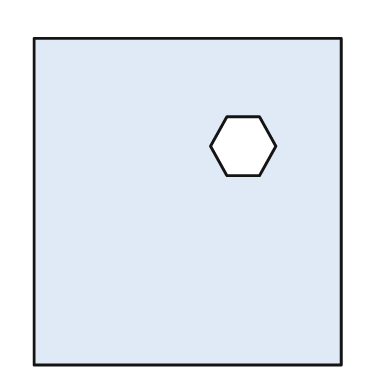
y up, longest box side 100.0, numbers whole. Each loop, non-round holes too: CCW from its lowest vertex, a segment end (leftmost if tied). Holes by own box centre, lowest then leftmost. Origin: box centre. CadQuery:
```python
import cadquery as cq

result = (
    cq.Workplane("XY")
    .moveTo(-47.0, -50.0)
    .lineTo(47.0, -50.0)
    .lineTo(47.0, 50.0)
    .lineTo(-47.0, 50.0)
    .close()
    .moveTo(12.0, 8.0)
    .lineTo(22.0, 8.0)
    .lineTo(27.0, 17.0)
    .lineTo(22.0, 26.0)
    .lineTo(12.0, 26.0)
    .lineTo(7.0, 17.0)
    .close()
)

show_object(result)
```